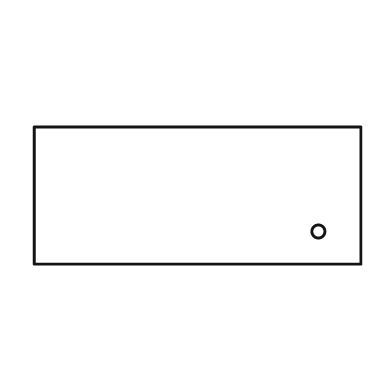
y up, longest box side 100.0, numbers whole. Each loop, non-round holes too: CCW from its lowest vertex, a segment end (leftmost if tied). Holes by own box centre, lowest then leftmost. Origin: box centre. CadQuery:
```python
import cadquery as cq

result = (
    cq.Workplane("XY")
    .moveTo(-50.0, -21.0)
    .lineTo(50.0, -21.0)
    .lineTo(50.0, 21.0)
    .lineTo(-50.0, 21.0)
    .close()
    .moveTo(37.0, -11.0)
    .circle(2.0)
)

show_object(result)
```